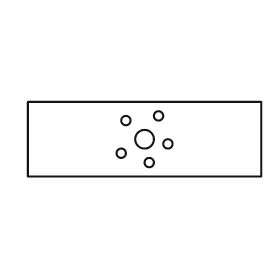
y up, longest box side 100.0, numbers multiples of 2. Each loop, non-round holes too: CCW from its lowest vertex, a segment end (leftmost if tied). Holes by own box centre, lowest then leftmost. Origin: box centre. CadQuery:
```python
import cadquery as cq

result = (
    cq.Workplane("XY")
    .moveTo(-50.0, -16.0)
    .lineTo(50.0, -16.0)
    .lineTo(50.0, 16.0)
    .lineTo(-50.0, 16.0)
    .close()
    .moveTo(2.0, -10.0)
    .circle(2.0)
    .moveTo(-10.0, -6.0)
    .circle(2.0)
    .moveTo(10.0, -2.0)
    .circle(2.0)
    .moveTo(0.0, 0.0)
    .circle(4.0)
    .moveTo(-8.0, 8.0)
    .circle(2.0)
    .moveTo(6.0, 10.0)
    .circle(2.0)
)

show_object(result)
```